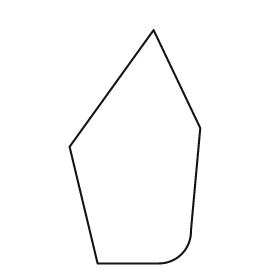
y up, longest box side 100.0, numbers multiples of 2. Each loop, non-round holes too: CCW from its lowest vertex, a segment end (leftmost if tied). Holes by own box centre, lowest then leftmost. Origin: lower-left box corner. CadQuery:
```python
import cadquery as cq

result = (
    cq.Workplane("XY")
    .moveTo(12.0, 0.0)
    .lineTo(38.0, 0.0)
    .threePointArc((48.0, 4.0), (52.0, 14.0))
    .lineTo(56.0, 58.0)
    .lineTo(36.0, 100.0)
    .lineTo(0.0, 50.0)
    .close()
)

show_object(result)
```